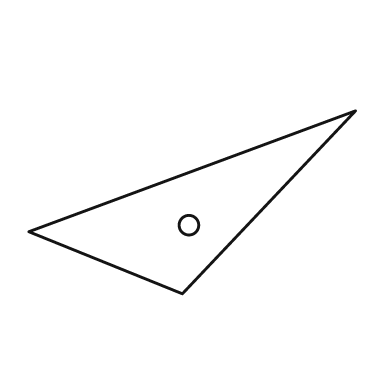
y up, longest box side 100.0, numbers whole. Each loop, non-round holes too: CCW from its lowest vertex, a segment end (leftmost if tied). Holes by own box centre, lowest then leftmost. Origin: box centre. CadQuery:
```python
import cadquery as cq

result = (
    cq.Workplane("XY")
    .moveTo(-3.0, -28.0)
    .lineTo(50.0, 28.0)
    .lineTo(-50.0, -9.0)
    .close()
    .moveTo(-1.0, -7.0)
    .circle(3.0)
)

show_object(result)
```